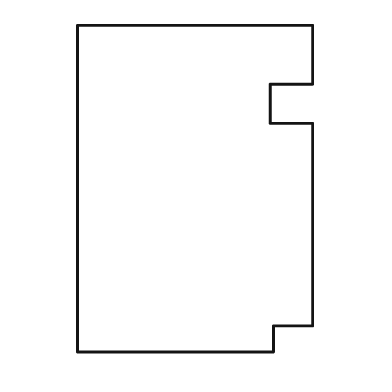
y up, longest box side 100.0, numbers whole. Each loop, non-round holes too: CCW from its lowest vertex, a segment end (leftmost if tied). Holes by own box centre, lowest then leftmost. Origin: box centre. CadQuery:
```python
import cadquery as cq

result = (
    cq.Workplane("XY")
    .moveTo(-36.0, -50.0)
    .lineTo(24.0, -50.0)
    .lineTo(24.0, -42.0)
    .lineTo(36.0, -42.0)
    .lineTo(36.0, 20.0)
    .lineTo(23.0, 20.0)
    .lineTo(23.0, 32.0)
    .lineTo(36.0, 32.0)
    .lineTo(36.0, 50.0)
    .lineTo(-36.0, 50.0)
    .close()
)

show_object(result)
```